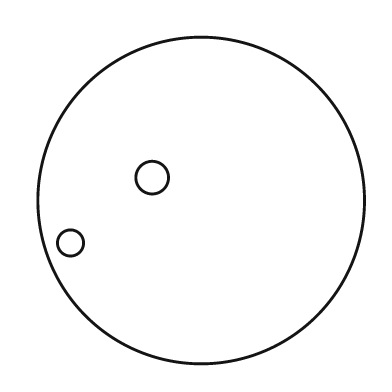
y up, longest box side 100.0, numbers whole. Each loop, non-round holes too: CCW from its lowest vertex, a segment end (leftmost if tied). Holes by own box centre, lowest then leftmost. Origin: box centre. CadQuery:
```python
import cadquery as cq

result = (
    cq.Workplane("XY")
    .moveTo(0.0, 0.0)
    .circle(50.0)
    .moveTo(-40.0, -13.0)
    .circle(4.0)
    .moveTo(-15.0, 7.0)
    .circle(5.0)
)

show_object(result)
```